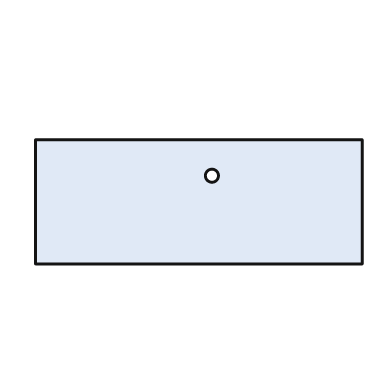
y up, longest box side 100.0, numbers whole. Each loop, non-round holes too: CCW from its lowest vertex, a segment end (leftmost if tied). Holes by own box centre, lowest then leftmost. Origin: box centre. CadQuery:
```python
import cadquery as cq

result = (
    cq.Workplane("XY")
    .moveTo(-50.0, -19.0)
    .lineTo(50.0, -19.0)
    .lineTo(50.0, 19.0)
    .lineTo(-50.0, 19.0)
    .close()
    .moveTo(4.0, 8.0)
    .circle(2.0)
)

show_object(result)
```